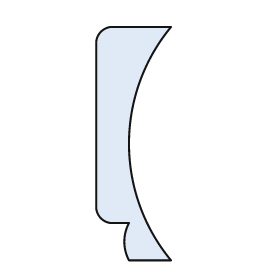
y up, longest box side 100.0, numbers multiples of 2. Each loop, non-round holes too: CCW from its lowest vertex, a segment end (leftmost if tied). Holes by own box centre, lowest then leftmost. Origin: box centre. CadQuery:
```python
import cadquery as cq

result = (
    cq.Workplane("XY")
    .moveTo(-2.0, -50.0)
    .lineTo(16.0, -50.0)
    .threePointArc((-2.0, 0.0), (16.0, 50.0))
    .lineTo(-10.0, 50.0)
    .threePointArc((-14.0, 48.0), (-16.0, 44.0))
    .lineTo(-16.0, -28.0)
    .threePointArc((-14.0, -32.0), (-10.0, -34.0))
    .lineTo(-2.0, -34.0)
    .threePointArc((-4.0, -42.0), (-2.0, -50.0))
    .close()
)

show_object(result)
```